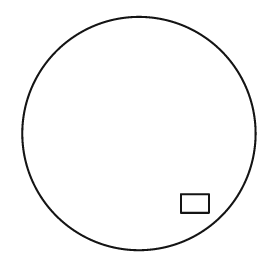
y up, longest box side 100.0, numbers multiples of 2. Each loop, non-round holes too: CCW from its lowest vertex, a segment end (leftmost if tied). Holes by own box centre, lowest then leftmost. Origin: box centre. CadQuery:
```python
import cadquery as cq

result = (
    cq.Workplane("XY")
    .moveTo(0.0, 0.0)
    .circle(50.0)
    .moveTo(18.0, -34.0)
    .lineTo(30.0, -34.0)
    .lineTo(30.0, -26.0)
    .lineTo(18.0, -26.0)
    .close()
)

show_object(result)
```